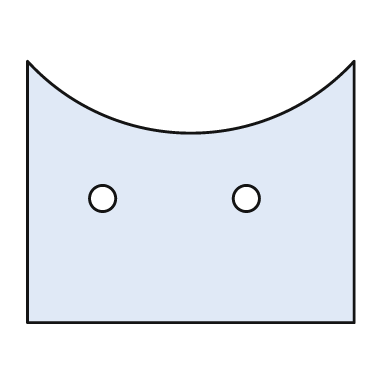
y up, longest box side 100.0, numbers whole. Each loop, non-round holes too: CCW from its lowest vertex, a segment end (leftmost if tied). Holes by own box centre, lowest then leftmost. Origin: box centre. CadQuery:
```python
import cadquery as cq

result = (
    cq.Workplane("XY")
    .moveTo(-50.0, -40.0)
    .lineTo(50.0, -40.0)
    .lineTo(50.0, 40.0)
    .threePointArc((0.0, 18.0), (-50.0, 40.0))
    .close()
    .moveTo(-27.0, -2.0)
    .circle(4.0)
    .moveTo(17.0, -2.0)
    .circle(4.0)
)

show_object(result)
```